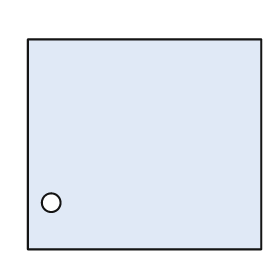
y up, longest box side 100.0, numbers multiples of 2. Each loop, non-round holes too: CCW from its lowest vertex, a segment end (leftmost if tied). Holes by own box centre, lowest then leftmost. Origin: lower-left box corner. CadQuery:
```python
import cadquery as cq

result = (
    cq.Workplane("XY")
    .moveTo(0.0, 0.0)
    .lineTo(100.0, 0.0)
    .lineTo(100.0, 90.0)
    .lineTo(0.0, 90.0)
    .close()
    .moveTo(10.0, 20.0)
    .circle(4.0)
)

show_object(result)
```